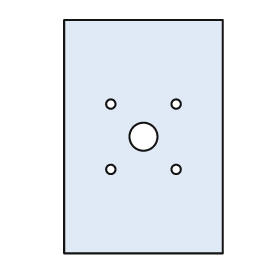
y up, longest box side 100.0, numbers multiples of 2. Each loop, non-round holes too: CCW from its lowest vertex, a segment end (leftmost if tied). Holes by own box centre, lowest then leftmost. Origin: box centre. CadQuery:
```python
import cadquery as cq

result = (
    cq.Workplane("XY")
    .moveTo(-34.0, -50.0)
    .lineTo(34.0, -50.0)
    .lineTo(34.0, 50.0)
    .lineTo(-34.0, 50.0)
    .close()
    .moveTo(-14.0, -14.0)
    .circle(2.0)
    .moveTo(14.0, -14.0)
    .circle(2.0)
    .moveTo(0.0, 0.0)
    .circle(6.0)
    .moveTo(-14.0, 14.0)
    .circle(2.0)
    .moveTo(14.0, 14.0)
    .circle(2.0)
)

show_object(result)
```